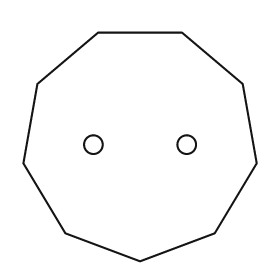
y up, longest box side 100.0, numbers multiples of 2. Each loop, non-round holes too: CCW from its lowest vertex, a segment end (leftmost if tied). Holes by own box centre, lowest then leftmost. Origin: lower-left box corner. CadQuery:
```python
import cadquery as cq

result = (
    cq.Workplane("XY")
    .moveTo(50.0, 0.0)
    .lineTo(82.0, 12.0)
    .lineTo(100.0, 42.0)
    .lineTo(94.0, 76.0)
    .lineTo(68.0, 98.0)
    .lineTo(32.0, 98.0)
    .lineTo(6.0, 76.0)
    .lineTo(0.0, 42.0)
    .lineTo(18.0, 12.0)
    .close()
    .moveTo(30.0, 50.0)
    .circle(4.0)
    .moveTo(70.0, 50.0)
    .circle(4.0)
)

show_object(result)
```